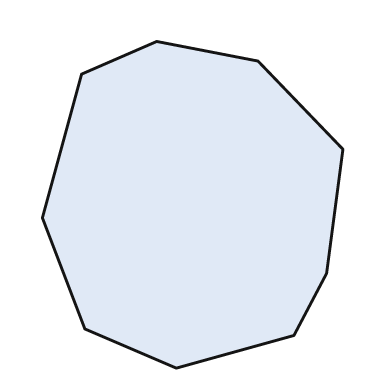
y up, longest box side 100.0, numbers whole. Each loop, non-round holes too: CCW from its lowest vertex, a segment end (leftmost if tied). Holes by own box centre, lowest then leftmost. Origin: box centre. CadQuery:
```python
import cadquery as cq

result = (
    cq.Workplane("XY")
    .moveTo(-5.0, -50.0)
    .lineTo(31.0, -40.0)
    .lineTo(41.0, -21.0)
    .lineTo(46.0, 17.0)
    .lineTo(20.0, 44.0)
    .lineTo(-11.0, 50.0)
    .lineTo(-34.0, 40.0)
    .lineTo(-46.0, -4.0)
    .lineTo(-33.0, -38.0)
    .close()
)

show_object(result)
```